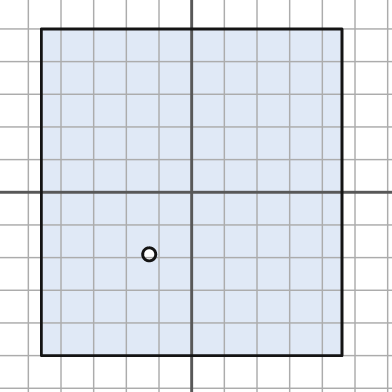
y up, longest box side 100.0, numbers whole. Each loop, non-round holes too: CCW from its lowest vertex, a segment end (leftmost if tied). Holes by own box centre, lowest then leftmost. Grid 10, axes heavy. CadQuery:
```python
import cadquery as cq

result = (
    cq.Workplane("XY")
    .moveTo(-46.0, -50.0)
    .lineTo(46.0, -50.0)
    .lineTo(46.0, 50.0)
    .lineTo(-46.0, 50.0)
    .close()
    .moveTo(-13.0, -19.0)
    .circle(2.0)
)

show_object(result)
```